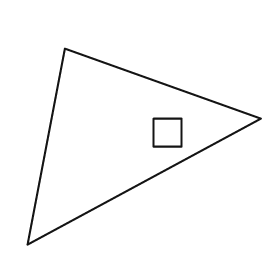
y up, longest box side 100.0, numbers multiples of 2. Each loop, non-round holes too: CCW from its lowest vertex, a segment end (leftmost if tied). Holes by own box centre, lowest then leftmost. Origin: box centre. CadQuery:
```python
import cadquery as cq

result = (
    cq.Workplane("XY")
    .moveTo(-50.0, -42.0)
    .lineTo(50.0, 12.0)
    .lineTo(-34.0, 42.0)
    .close()
    .moveTo(4.0, 0.0)
    .lineTo(16.0, 0.0)
    .lineTo(16.0, 12.0)
    .lineTo(4.0, 12.0)
    .close()
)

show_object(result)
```